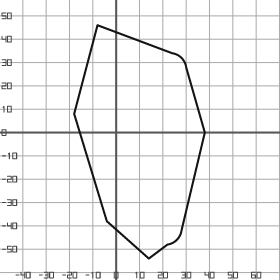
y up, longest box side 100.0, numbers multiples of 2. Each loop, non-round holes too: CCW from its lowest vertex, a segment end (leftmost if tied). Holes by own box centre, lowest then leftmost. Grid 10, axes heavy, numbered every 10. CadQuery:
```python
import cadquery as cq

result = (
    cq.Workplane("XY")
    .moveTo(14.0, -54.0)
    .lineTo(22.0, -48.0)
    .threePointArc((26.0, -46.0), (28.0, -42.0))
    .lineTo(38.0, 0.0)
    .lineTo(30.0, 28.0)
    .threePointArc((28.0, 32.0), (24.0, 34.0))
    .lineTo(-8.0, 46.0)
    .lineTo(-18.0, 8.0)
    .lineTo(-4.0, -38.0)
    .close()
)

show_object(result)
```